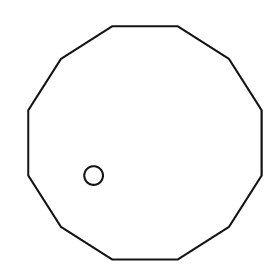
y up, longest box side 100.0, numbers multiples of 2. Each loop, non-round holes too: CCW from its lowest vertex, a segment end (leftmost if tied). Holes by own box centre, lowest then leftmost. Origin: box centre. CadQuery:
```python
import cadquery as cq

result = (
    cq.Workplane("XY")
    .moveTo(-14.0, -50.0)
    .lineTo(14.0, -50.0)
    .lineTo(36.0, -36.0)
    .lineTo(50.0, -14.0)
    .lineTo(50.0, 14.0)
    .lineTo(36.0, 36.0)
    .lineTo(14.0, 50.0)
    .lineTo(-14.0, 50.0)
    .lineTo(-36.0, 36.0)
    .lineTo(-50.0, 14.0)
    .lineTo(-50.0, -14.0)
    .lineTo(-36.0, -36.0)
    .close()
    .moveTo(-22.0, -14.0)
    .circle(4.0)
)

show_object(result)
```